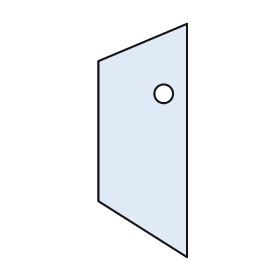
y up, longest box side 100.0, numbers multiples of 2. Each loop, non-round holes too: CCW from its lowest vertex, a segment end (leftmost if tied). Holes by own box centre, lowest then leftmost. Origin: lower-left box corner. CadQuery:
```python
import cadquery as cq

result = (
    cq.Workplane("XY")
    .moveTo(38.0, 0.0)
    .lineTo(38.0, 100.0)
    .lineTo(0.0, 84.0)
    .lineTo(0.0, 24.0)
    .close()
    .moveTo(28.0, 70.0)
    .circle(4.0)
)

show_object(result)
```